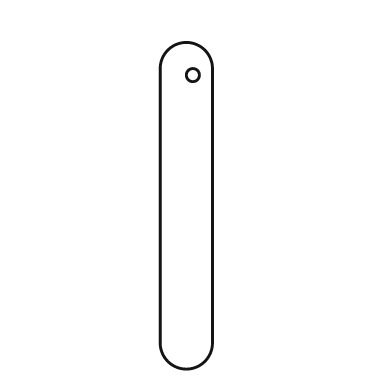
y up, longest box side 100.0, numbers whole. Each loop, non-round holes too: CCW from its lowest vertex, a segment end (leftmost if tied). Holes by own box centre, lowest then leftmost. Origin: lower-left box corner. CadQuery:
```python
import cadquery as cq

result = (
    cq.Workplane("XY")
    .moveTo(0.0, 8.0)
    .threePointArc((8.0, 0.0), (16.0, 8.0))
    .lineTo(16.0, 92.0)
    .threePointArc((8.0, 100.0), (0.0, 92.0))
    .close()
    .moveTo(10.0, 90.0)
    .circle(2.0)
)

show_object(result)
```